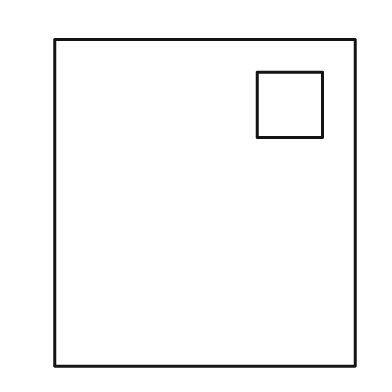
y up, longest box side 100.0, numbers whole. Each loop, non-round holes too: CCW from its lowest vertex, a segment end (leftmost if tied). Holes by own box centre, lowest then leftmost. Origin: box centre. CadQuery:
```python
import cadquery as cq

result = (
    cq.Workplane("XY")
    .moveTo(-46.0, -50.0)
    .lineTo(46.0, -50.0)
    .lineTo(46.0, 50.0)
    .lineTo(-46.0, 50.0)
    .close()
    .moveTo(16.0, 20.0)
    .lineTo(36.0, 20.0)
    .lineTo(36.0, 40.0)
    .lineTo(16.0, 40.0)
    .close()
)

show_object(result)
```